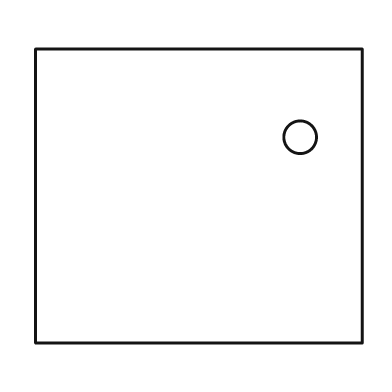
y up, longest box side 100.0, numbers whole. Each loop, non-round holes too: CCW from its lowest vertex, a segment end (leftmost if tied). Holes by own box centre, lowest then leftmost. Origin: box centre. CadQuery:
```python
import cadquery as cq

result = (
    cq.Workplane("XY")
    .moveTo(-50.0, -45.0)
    .lineTo(50.0, -45.0)
    .lineTo(50.0, 45.0)
    .lineTo(-50.0, 45.0)
    .close()
    .moveTo(31.0, 18.0)
    .circle(5.0)
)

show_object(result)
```